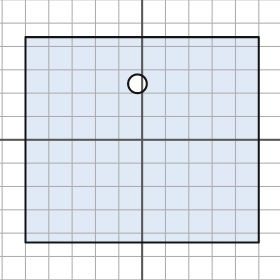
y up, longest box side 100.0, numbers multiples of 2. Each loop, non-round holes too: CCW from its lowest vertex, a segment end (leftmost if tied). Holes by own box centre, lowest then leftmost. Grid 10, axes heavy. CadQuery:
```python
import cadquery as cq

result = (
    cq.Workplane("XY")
    .moveTo(-50.0, -44.0)
    .lineTo(50.0, -44.0)
    .lineTo(50.0, 44.0)
    .lineTo(-50.0, 44.0)
    .close()
    .moveTo(-2.0, 24.0)
    .circle(4.0)
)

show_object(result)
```